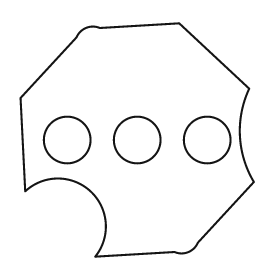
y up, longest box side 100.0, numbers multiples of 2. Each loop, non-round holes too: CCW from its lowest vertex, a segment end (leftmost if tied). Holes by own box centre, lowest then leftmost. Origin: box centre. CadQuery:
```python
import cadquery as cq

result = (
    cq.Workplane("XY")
    .moveTo(-18.0, -50.0)
    .lineTo(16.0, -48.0)
    .threePointArc((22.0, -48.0), (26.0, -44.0))
    .lineTo(50.0, -18.0)
    .threePointArc((44.0, 2.0), (48.0, 22.0))
    .lineTo(18.0, 50.0)
    .lineTo(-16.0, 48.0)
    .threePointArc((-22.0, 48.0), (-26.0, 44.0))
    .lineTo(-50.0, 18.0)
    .lineTo(-48.0, -22.0)
    .threePointArc((-20.0, -22.0), (-18.0, -50.0))
    .close()
    .moveTo(-30.0, 0.0)
    .circle(10.0)
    .moveTo(0.0, 0.0)
    .circle(10.0)
    .moveTo(30.0, 0.0)
    .circle(10.0)
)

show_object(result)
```